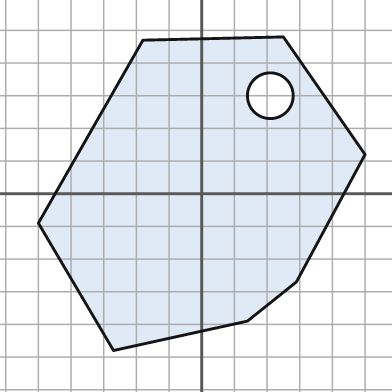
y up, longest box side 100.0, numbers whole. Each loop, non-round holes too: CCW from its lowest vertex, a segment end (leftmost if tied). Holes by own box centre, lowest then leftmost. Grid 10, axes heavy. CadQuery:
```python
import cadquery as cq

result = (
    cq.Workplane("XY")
    .moveTo(-27.0, -48.0)
    .lineTo(14.0, -39.0)
    .lineTo(29.0, -27.0)
    .lineTo(50.0, 12.0)
    .lineTo(25.0, 48.0)
    .lineTo(-18.0, 47.0)
    .lineTo(-50.0, -9.0)
    .close()
    .moveTo(21.0, 30.0)
    .circle(7.0)
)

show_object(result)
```